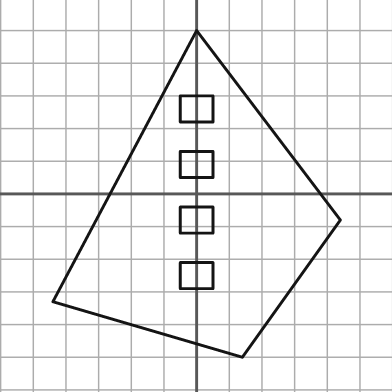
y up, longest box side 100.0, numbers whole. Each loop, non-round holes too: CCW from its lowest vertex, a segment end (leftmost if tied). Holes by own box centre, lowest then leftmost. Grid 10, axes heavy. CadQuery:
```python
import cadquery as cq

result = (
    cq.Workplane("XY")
    .moveTo(14.0, -50.0)
    .lineTo(44.0, -8.0)
    .lineTo(0.0, 50.0)
    .lineTo(-44.0, -33.0)
    .close()
    .moveTo(-5.0, -29.0)
    .lineTo(5.0, -29.0)
    .lineTo(5.0, -21.0)
    .lineTo(-5.0, -21.0)
    .close()
    .moveTo(-5.0, -12.0)
    .lineTo(5.0, -12.0)
    .lineTo(5.0, -4.0)
    .lineTo(-5.0, -4.0)
    .close()
    .moveTo(-5.0, 5.0)
    .lineTo(5.0, 5.0)
    .lineTo(5.0, 13.0)
    .lineTo(-5.0, 13.0)
    .close()
    .moveTo(-5.0, 22.0)
    .lineTo(5.0, 22.0)
    .lineTo(5.0, 30.0)
    .lineTo(-5.0, 30.0)
    .close()
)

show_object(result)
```